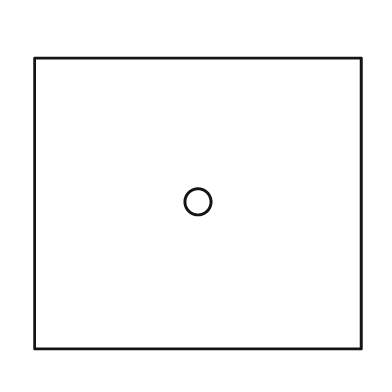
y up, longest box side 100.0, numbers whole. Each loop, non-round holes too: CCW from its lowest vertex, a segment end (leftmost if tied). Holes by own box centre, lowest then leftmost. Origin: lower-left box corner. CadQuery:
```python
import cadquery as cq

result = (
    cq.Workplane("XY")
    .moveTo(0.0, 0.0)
    .lineTo(100.0, 0.0)
    .lineTo(100.0, 89.0)
    .lineTo(0.0, 89.0)
    .close()
    .moveTo(50.0, 45.0)
    .circle(4.0)
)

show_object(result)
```